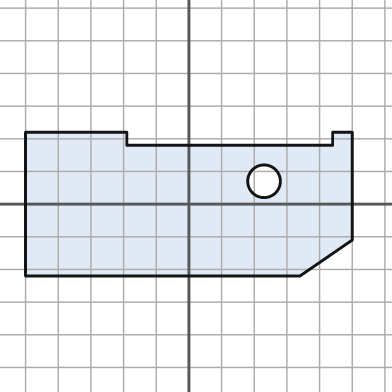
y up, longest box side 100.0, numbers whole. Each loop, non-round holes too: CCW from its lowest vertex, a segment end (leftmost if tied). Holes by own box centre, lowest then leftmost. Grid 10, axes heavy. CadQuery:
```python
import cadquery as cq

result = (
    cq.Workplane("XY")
    .moveTo(-50.0, -22.0)
    .lineTo(34.0, -22.0)
    .lineTo(50.0, -11.0)
    .lineTo(50.0, 22.0)
    .lineTo(44.0, 22.0)
    .lineTo(44.0, 18.0)
    .lineTo(-19.0, 18.0)
    .lineTo(-19.0, 22.0)
    .lineTo(-50.0, 22.0)
    .close()
    .moveTo(23.0, 7.0)
    .circle(5.0)
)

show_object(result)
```